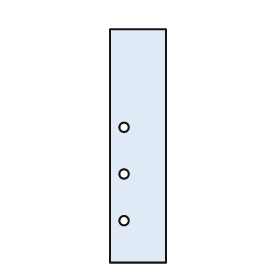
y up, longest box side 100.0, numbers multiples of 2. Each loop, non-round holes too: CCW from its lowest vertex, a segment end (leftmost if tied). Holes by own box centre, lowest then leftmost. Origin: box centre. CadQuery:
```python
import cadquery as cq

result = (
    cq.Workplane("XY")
    .moveTo(-12.0, -50.0)
    .lineTo(12.0, -50.0)
    .lineTo(12.0, 50.0)
    .lineTo(-12.0, 50.0)
    .close()
    .moveTo(-6.0, -32.0)
    .circle(2.0)
    .moveTo(-6.0, -12.0)
    .circle(2.0)
    .moveTo(-6.0, 8.0)
    .circle(2.0)
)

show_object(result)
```